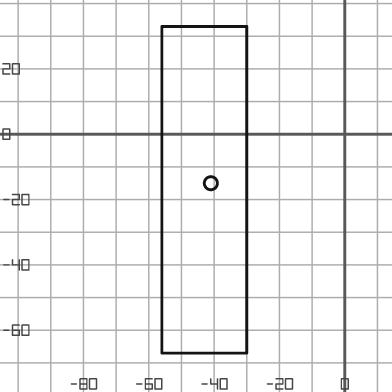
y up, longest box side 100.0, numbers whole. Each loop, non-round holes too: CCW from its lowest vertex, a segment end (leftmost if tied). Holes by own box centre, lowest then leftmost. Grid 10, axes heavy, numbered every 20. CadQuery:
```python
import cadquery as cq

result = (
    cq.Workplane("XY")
    .moveTo(-56.0, -67.0)
    .lineTo(-30.0, -67.0)
    .lineTo(-30.0, 33.0)
    .lineTo(-56.0, 33.0)
    .close()
    .moveTo(-41.0, -15.0)
    .circle(2.0)
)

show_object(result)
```